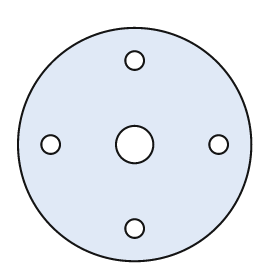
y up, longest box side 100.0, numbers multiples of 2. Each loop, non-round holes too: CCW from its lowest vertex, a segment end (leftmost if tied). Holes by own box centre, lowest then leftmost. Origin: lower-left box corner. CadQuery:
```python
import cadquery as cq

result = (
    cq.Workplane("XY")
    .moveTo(50.0, 50.0)
    .circle(50.0)
    .moveTo(50.0, 14.0)
    .circle(4.0)
    .moveTo(14.0, 50.0)
    .circle(4.0)
    .moveTo(50.0, 50.0)
    .circle(8.0)
    .moveTo(86.0, 50.0)
    .circle(4.0)
    .moveTo(50.0, 86.0)
    .circle(4.0)
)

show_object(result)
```